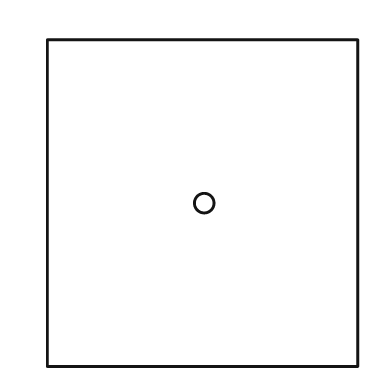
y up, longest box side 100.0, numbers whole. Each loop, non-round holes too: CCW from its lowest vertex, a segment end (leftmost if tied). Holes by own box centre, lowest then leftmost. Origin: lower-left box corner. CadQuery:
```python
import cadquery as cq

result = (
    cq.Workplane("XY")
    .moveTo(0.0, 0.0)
    .lineTo(95.0, 0.0)
    .lineTo(95.0, 100.0)
    .lineTo(0.0, 100.0)
    .close()
    .moveTo(48.0, 50.0)
    .circle(3.0)
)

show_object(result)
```